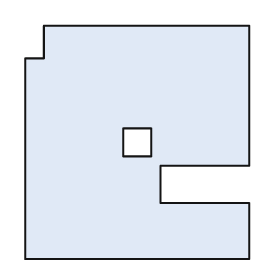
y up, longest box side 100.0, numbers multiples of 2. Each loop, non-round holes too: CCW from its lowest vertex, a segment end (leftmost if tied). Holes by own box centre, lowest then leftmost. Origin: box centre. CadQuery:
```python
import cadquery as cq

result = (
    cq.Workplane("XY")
    .moveTo(-48.0, -50.0)
    .lineTo(48.0, -50.0)
    .lineTo(48.0, -26.0)
    .lineTo(10.0, -26.0)
    .lineTo(10.0, -10.0)
    .lineTo(48.0, -10.0)
    .lineTo(48.0, 50.0)
    .lineTo(-40.0, 50.0)
    .lineTo(-40.0, 36.0)
    .lineTo(-48.0, 36.0)
    .close()
    .moveTo(-6.0, -6.0)
    .lineTo(6.0, -6.0)
    .lineTo(6.0, 6.0)
    .lineTo(-6.0, 6.0)
    .close()
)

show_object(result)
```